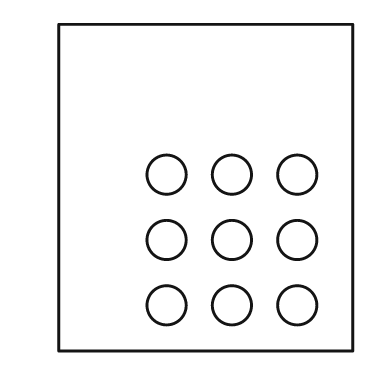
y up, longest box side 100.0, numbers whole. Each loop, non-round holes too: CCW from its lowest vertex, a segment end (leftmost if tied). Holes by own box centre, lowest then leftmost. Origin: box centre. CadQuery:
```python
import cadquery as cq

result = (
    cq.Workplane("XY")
    .moveTo(-45.0, -50.0)
    .lineTo(45.0, -50.0)
    .lineTo(45.0, 50.0)
    .lineTo(-45.0, 50.0)
    .close()
    .moveTo(-12.0, -36.0)
    .circle(6.0)
    .moveTo(8.0, -36.0)
    .circle(6.0)
    .moveTo(28.0, -36.0)
    .circle(6.0)
    .moveTo(-12.0, -16.0)
    .circle(6.0)
    .moveTo(8.0, -16.0)
    .circle(6.0)
    .moveTo(28.0, -16.0)
    .circle(6.0)
    .moveTo(-12.0, 4.0)
    .circle(6.0)
    .moveTo(8.0, 4.0)
    .circle(6.0)
    .moveTo(28.0, 4.0)
    .circle(6.0)
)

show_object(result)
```